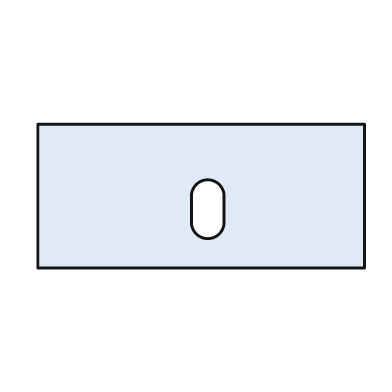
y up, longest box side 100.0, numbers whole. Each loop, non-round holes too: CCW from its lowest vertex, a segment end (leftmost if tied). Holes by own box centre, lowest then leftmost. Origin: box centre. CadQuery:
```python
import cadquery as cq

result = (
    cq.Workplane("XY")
    .moveTo(-50.0, -22.0)
    .lineTo(50.0, -22.0)
    .lineTo(50.0, 22.0)
    .lineTo(-50.0, 22.0)
    .close()
    .moveTo(-3.0, -8.0)
    .threePointArc((2.0, -13.0), (7.0, -8.0))
    .lineTo(7.0, 0.0)
    .threePointArc((2.0, 5.0), (-3.0, 0.0))
    .close()
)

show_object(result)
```